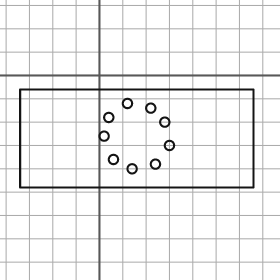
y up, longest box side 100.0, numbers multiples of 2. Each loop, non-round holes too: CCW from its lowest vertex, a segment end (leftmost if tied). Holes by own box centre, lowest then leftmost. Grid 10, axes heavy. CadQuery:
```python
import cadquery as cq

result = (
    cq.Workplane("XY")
    .moveTo(-34.0, -48.0)
    .lineTo(66.0, -48.0)
    .lineTo(66.0, -6.0)
    .lineTo(-34.0, -6.0)
    .close()
    .moveTo(14.0, -40.0)
    .circle(2.0)
    .moveTo(24.0, -38.0)
    .circle(2.0)
    .moveTo(6.0, -36.0)
    .circle(2.0)
    .moveTo(30.0, -30.0)
    .circle(2.0)
    .moveTo(2.0, -26.0)
    .circle(2.0)
    .moveTo(28.0, -20.0)
    .circle(2.0)
    .moveTo(4.0, -18.0)
    .circle(2.0)
    .moveTo(22.0, -14.0)
    .circle(2.0)
    .moveTo(12.0, -12.0)
    .circle(2.0)
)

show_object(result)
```